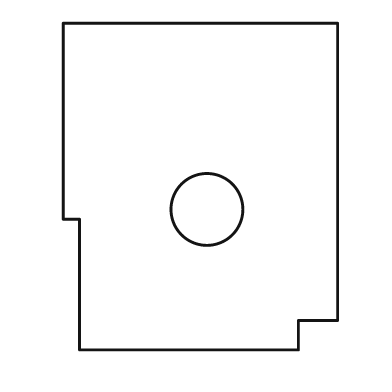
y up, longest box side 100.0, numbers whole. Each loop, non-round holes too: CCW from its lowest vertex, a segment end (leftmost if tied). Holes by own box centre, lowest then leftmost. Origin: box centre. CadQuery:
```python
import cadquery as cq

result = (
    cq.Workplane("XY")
    .moveTo(-37.0, -50.0)
    .lineTo(30.0, -50.0)
    .lineTo(30.0, -41.0)
    .lineTo(42.0, -41.0)
    .lineTo(42.0, 50.0)
    .lineTo(-42.0, 50.0)
    .lineTo(-42.0, -10.0)
    .lineTo(-37.0, -10.0)
    .close()
    .moveTo(2.0, -7.0)
    .circle(11.0)
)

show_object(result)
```